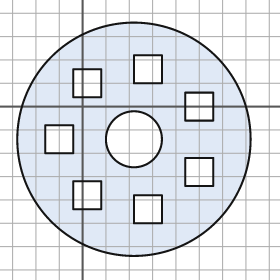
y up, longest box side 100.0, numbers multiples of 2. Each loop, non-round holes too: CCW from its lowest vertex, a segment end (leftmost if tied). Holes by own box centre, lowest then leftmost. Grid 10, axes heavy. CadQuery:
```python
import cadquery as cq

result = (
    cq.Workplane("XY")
    .moveTo(22.0, -14.0)
    .circle(50.0)
    .moveTo(22.0, -50.0)
    .lineTo(34.0, -50.0)
    .lineTo(34.0, -38.0)
    .lineTo(22.0, -38.0)
    .close()
    .moveTo(-4.0, -44.0)
    .lineTo(8.0, -44.0)
    .lineTo(8.0, -32.0)
    .lineTo(-4.0, -32.0)
    .close()
    .moveTo(44.0, -34.0)
    .lineTo(56.0, -34.0)
    .lineTo(56.0, -22.0)
    .lineTo(44.0, -22.0)
    .close()
    .moveTo(-16.0, -20.0)
    .lineTo(-4.0, -20.0)
    .lineTo(-4.0, -8.0)
    .lineTo(-16.0, -8.0)
    .close()
    .moveTo(22.0, -14.0)
    .circle(12.0)
    .moveTo(44.0, -6.0)
    .lineTo(56.0, -6.0)
    .lineTo(56.0, 6.0)
    .lineTo(44.0, 6.0)
    .close()
    .moveTo(-4.0, 4.0)
    .lineTo(8.0, 4.0)
    .lineTo(8.0, 16.0)
    .lineTo(-4.0, 16.0)
    .close()
    .moveTo(22.0, 10.0)
    .lineTo(34.0, 10.0)
    .lineTo(34.0, 22.0)
    .lineTo(22.0, 22.0)
    .close()
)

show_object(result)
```